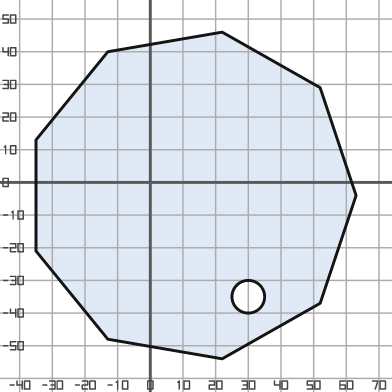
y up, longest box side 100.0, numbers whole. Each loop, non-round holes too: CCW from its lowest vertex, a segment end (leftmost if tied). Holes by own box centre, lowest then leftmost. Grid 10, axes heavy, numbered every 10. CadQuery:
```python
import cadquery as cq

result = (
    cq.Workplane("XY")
    .moveTo(22.0, -54.0)
    .lineTo(52.0, -37.0)
    .lineTo(63.0, -4.0)
    .lineTo(52.0, 29.0)
    .lineTo(22.0, 46.0)
    .lineTo(-13.0, 40.0)
    .lineTo(-35.0, 13.0)
    .lineTo(-35.0, -21.0)
    .lineTo(-13.0, -48.0)
    .close()
    .moveTo(30.0, -35.0)
    .circle(5.0)
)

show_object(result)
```